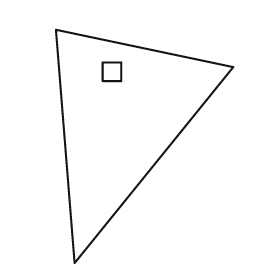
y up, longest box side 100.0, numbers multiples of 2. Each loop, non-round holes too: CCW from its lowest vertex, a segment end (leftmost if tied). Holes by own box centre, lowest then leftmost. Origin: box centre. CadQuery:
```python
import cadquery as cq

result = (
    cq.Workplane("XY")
    .moveTo(-30.0, -50.0)
    .lineTo(38.0, 34.0)
    .lineTo(-38.0, 50.0)
    .close()
    .moveTo(-18.0, 28.0)
    .lineTo(-10.0, 28.0)
    .lineTo(-10.0, 36.0)
    .lineTo(-18.0, 36.0)
    .close()
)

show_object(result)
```